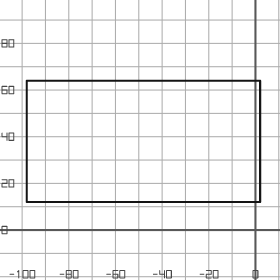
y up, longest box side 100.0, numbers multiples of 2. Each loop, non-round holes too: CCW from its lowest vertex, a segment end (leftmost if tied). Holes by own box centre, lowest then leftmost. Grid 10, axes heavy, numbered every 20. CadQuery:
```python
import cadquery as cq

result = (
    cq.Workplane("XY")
    .moveTo(-98.0, 12.0)
    .lineTo(2.0, 12.0)
    .lineTo(2.0, 64.0)
    .lineTo(-98.0, 64.0)
    .close()
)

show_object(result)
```